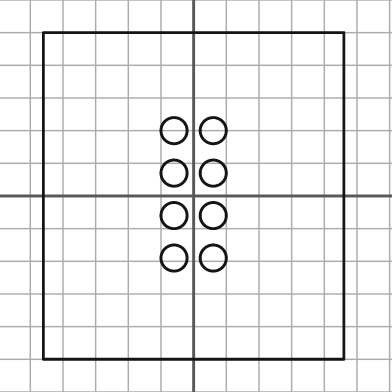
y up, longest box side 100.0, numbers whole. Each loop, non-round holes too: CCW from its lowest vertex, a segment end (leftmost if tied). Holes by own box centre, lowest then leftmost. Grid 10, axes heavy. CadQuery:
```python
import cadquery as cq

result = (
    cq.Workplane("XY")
    .moveTo(-46.0, -50.0)
    .lineTo(46.0, -50.0)
    .lineTo(46.0, 50.0)
    .lineTo(-46.0, 50.0)
    .close()
    .moveTo(-6.0, -19.0)
    .circle(4.0)
    .moveTo(6.0, -19.0)
    .circle(4.0)
    .moveTo(-6.0, -6.0)
    .circle(4.0)
    .moveTo(6.0, -6.0)
    .circle(4.0)
    .moveTo(-6.0, 7.0)
    .circle(4.0)
    .moveTo(6.0, 7.0)
    .circle(4.0)
    .moveTo(-6.0, 20.0)
    .circle(4.0)
    .moveTo(6.0, 20.0)
    .circle(4.0)
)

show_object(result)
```